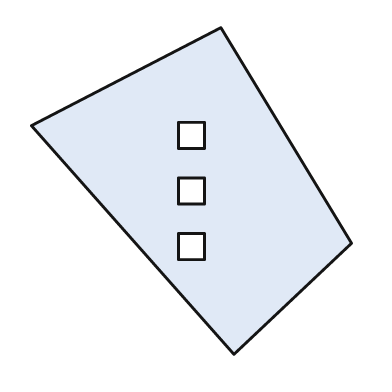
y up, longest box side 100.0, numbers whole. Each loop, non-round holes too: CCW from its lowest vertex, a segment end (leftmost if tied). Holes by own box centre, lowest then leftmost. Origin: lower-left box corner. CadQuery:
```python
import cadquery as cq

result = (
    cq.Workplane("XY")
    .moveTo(62.0, 0.0)
    .lineTo(98.0, 34.0)
    .lineTo(58.0, 100.0)
    .lineTo(0.0, 70.0)
    .close()
    .moveTo(45.0, 29.0)
    .lineTo(53.0, 29.0)
    .lineTo(53.0, 37.0)
    .lineTo(45.0, 37.0)
    .close()
    .moveTo(45.0, 46.0)
    .lineTo(53.0, 46.0)
    .lineTo(53.0, 54.0)
    .lineTo(45.0, 54.0)
    .close()
    .moveTo(45.0, 63.0)
    .lineTo(53.0, 63.0)
    .lineTo(53.0, 71.0)
    .lineTo(45.0, 71.0)
    .close()
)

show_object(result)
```